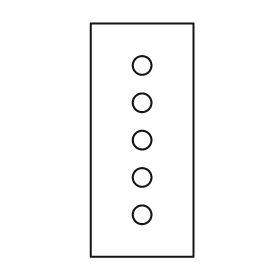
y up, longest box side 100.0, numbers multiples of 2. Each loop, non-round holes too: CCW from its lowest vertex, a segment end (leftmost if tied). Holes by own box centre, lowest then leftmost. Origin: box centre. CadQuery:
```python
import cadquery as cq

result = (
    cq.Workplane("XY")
    .moveTo(-22.0, -50.0)
    .lineTo(22.0, -50.0)
    .lineTo(22.0, 50.0)
    .lineTo(-22.0, 50.0)
    .close()
    .moveTo(0.0, -32.0)
    .circle(4.0)
    .moveTo(0.0, -16.0)
    .circle(4.0)
    .moveTo(0.0, 0.0)
    .circle(4.0)
    .moveTo(0.0, 16.0)
    .circle(4.0)
    .moveTo(0.0, 32.0)
    .circle(4.0)
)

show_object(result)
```